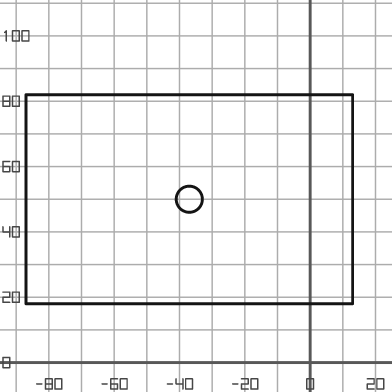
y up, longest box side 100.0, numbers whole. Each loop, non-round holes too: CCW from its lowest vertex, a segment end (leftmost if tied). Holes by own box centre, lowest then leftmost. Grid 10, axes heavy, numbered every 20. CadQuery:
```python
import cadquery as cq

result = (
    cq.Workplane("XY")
    .moveTo(-87.0, 18.0)
    .lineTo(13.0, 18.0)
    .lineTo(13.0, 82.0)
    .lineTo(-87.0, 82.0)
    .close()
    .moveTo(-37.0, 50.0)
    .circle(4.0)
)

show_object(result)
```